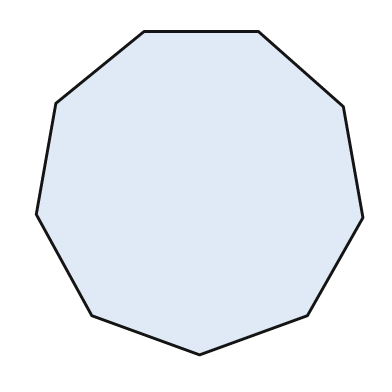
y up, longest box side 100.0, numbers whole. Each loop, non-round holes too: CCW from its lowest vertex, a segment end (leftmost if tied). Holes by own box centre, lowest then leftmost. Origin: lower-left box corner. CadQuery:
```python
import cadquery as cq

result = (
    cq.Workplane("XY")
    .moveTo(50.0, 0.0)
    .lineTo(83.0, 12.0)
    .lineTo(100.0, 42.0)
    .lineTo(94.0, 76.0)
    .lineTo(68.0, 99.0)
    .lineTo(33.0, 99.0)
    .lineTo(6.0, 77.0)
    .lineTo(0.0, 43.0)
    .lineTo(17.0, 12.0)
    .close()
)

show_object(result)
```